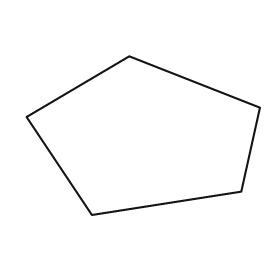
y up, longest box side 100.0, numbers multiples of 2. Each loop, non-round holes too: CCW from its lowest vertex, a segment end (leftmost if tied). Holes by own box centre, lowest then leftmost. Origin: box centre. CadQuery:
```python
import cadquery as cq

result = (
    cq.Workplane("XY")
    .moveTo(-22.0, -34.0)
    .lineTo(42.0, -24.0)
    .lineTo(50.0, 12.0)
    .lineTo(-6.0, 34.0)
    .lineTo(-50.0, 8.0)
    .close()
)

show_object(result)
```